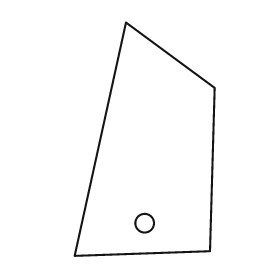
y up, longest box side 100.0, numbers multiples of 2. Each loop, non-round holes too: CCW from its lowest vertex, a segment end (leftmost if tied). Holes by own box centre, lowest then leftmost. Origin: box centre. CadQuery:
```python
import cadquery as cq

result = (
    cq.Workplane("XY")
    .moveTo(-30.0, -50.0)
    .lineTo(28.0, -48.0)
    .lineTo(30.0, 22.0)
    .lineTo(-8.0, 50.0)
    .close()
    .moveTo(0.0, -36.0)
    .circle(4.0)
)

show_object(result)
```